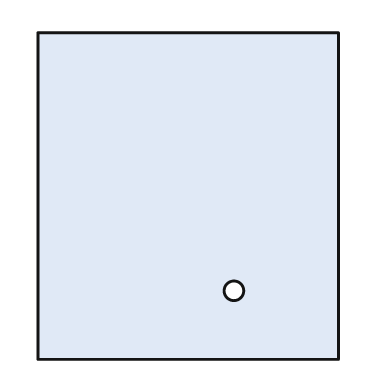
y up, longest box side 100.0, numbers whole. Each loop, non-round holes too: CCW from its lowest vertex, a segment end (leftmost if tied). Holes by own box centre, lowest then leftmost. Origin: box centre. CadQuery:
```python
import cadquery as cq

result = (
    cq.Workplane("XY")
    .moveTo(-46.0, -50.0)
    .lineTo(46.0, -50.0)
    .lineTo(46.0, 50.0)
    .lineTo(-46.0, 50.0)
    .close()
    .moveTo(14.0, -29.0)
    .circle(3.0)
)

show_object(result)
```